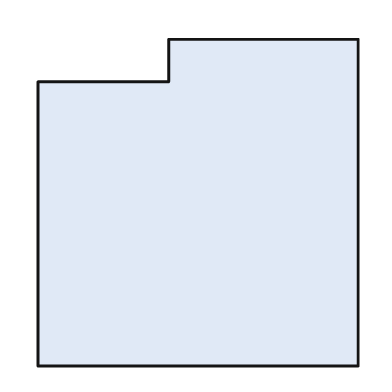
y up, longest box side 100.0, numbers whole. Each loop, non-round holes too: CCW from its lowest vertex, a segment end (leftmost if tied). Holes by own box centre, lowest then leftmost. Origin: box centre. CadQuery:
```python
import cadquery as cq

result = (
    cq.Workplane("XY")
    .moveTo(-49.0, -50.0)
    .lineTo(49.0, -50.0)
    .lineTo(49.0, 50.0)
    .lineTo(-9.0, 50.0)
    .lineTo(-9.0, 37.0)
    .lineTo(-49.0, 37.0)
    .close()
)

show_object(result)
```